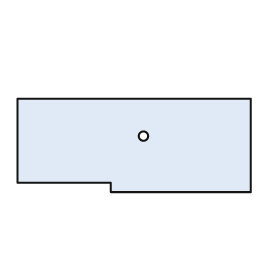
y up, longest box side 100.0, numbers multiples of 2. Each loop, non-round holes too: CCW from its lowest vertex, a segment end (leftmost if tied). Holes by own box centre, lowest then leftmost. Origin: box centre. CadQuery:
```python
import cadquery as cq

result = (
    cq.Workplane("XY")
    .moveTo(-10.0, -20.0)
    .lineTo(50.0, -20.0)
    .lineTo(50.0, 20.0)
    .lineTo(-50.0, 20.0)
    .lineTo(-50.0, -16.0)
    .lineTo(-10.0, -16.0)
    .close()
    .moveTo(4.0, 4.0)
    .circle(2.0)
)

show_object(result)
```